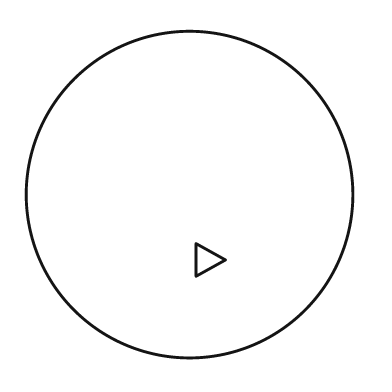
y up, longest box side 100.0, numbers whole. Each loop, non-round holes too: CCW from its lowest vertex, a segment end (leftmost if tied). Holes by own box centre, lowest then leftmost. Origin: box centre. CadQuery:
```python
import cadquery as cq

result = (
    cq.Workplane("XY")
    .moveTo(0.0, 0.0)
    .circle(50.0)
    .moveTo(2.0, -25.0)
    .lineTo(11.0, -20.0)
    .lineTo(2.0, -15.0)
    .close()
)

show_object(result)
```